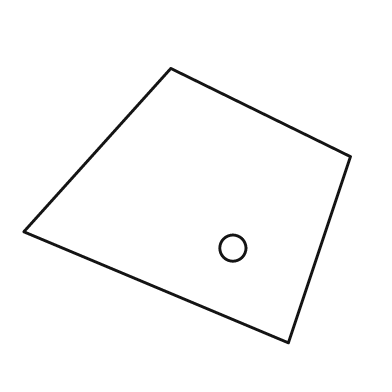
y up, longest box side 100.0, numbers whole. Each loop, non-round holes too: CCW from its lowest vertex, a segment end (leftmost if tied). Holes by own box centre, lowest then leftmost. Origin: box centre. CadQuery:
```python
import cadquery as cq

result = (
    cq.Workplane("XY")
    .moveTo(31.0, -42.0)
    .lineTo(50.0, 15.0)
    .lineTo(-5.0, 42.0)
    .lineTo(-50.0, -8.0)
    .close()
    .moveTo(14.0, -13.0)
    .circle(4.0)
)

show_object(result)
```